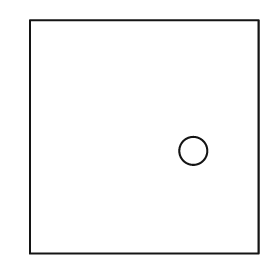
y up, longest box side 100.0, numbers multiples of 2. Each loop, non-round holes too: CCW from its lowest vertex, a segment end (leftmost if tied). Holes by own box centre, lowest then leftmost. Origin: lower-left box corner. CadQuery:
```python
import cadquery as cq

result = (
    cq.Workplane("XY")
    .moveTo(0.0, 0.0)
    .lineTo(98.0, 0.0)
    .lineTo(98.0, 100.0)
    .lineTo(0.0, 100.0)
    .close()
    .moveTo(70.0, 44.0)
    .circle(6.0)
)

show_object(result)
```